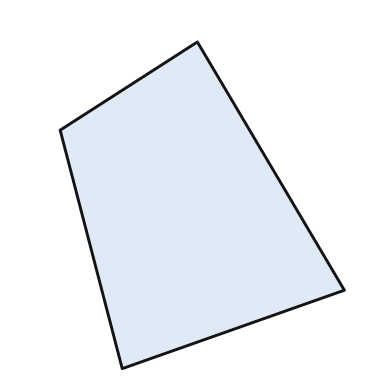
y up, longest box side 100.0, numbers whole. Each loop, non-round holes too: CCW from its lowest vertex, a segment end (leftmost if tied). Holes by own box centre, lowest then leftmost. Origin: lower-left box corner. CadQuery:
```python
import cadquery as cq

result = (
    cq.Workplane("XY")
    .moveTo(19.0, 0.0)
    .lineTo(87.0, 24.0)
    .lineTo(42.0, 100.0)
    .lineTo(0.0, 73.0)
    .close()
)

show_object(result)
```